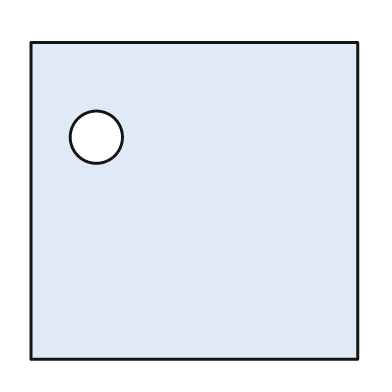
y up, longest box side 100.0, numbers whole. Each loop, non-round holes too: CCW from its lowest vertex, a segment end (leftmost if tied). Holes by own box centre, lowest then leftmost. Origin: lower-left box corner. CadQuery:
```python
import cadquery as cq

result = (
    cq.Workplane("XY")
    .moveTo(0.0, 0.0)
    .lineTo(100.0, 0.0)
    .lineTo(100.0, 97.0)
    .lineTo(0.0, 97.0)
    .close()
    .moveTo(20.0, 68.0)
    .circle(8.0)
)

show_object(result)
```